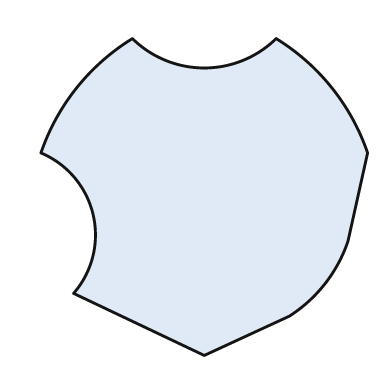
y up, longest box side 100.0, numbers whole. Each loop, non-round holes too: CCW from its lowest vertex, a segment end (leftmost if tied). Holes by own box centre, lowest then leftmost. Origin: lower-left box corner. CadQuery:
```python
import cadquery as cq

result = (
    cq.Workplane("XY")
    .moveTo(50.0, 0.0)
    .lineTo(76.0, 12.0)
    .threePointArc((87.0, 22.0), (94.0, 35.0))
    .lineTo(100.0, 62.0)
    .threePointArc((89.0, 82.0), (72.0, 97.0))
    .threePointArc((50.0, 88.0), (28.0, 97.0))
    .threePointArc((11.0, 82.0), (0.0, 62.0))
    .threePointArc((16.0, 43.0), (10.0, 19.0))
    .close()
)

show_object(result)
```